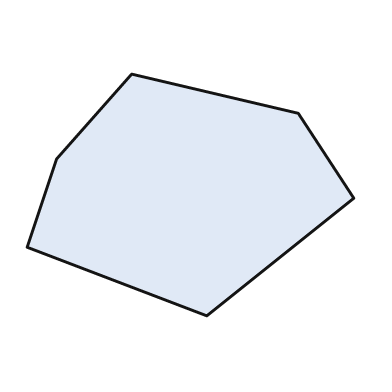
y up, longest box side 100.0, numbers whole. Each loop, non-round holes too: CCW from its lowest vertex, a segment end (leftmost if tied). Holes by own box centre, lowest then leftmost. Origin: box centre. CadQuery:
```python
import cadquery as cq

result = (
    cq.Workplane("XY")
    .moveTo(5.0, -37.0)
    .lineTo(50.0, -1.0)
    .lineTo(33.0, 25.0)
    .lineTo(-18.0, 37.0)
    .lineTo(-41.0, 11.0)
    .lineTo(-50.0, -16.0)
    .close()
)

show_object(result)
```